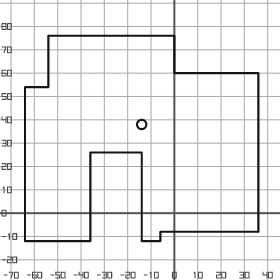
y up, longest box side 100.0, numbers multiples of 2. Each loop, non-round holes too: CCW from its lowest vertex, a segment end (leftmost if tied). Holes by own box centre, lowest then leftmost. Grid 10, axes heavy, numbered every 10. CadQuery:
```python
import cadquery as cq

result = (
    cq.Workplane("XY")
    .moveTo(-64.0, -12.0)
    .lineTo(-36.0, -12.0)
    .lineTo(-36.0, 26.0)
    .lineTo(-14.0, 26.0)
    .lineTo(-14.0, -12.0)
    .lineTo(-6.0, -12.0)
    .lineTo(-6.0, -8.0)
    .lineTo(36.0, -8.0)
    .lineTo(36.0, 60.0)
    .lineTo(0.0, 60.0)
    .lineTo(0.0, 76.0)
    .lineTo(-54.0, 76.0)
    .lineTo(-54.0, 54.0)
    .lineTo(-64.0, 54.0)
    .close()
    .moveTo(-14.0, 38.0)
    .circle(2.0)
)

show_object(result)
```